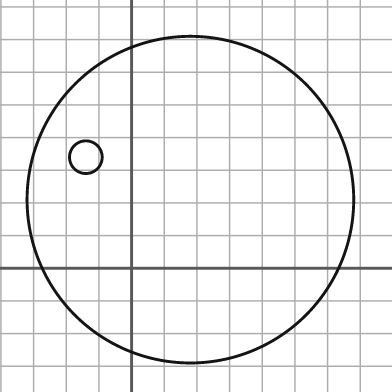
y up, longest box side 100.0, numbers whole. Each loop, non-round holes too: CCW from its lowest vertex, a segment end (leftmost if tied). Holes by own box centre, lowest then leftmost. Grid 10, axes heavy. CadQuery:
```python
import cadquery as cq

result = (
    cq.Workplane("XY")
    .moveTo(18.0, 21.0)
    .circle(50.0)
    .moveTo(-14.0, 34.0)
    .circle(5.0)
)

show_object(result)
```